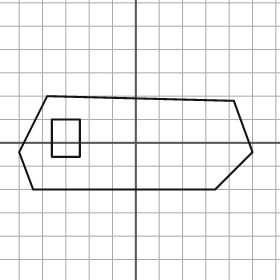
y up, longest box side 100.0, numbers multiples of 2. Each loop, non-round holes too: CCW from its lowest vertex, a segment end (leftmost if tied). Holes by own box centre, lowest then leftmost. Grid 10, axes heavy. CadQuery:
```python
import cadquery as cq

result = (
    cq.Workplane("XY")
    .moveTo(-44.0, -20.0)
    .lineTo(34.0, -20.0)
    .lineTo(50.0, -4.0)
    .lineTo(42.0, 18.0)
    .lineTo(-38.0, 20.0)
    .lineTo(-50.0, -4.0)
    .close()
    .moveTo(-36.0, -6.0)
    .lineTo(-24.0, -6.0)
    .lineTo(-24.0, 10.0)
    .lineTo(-36.0, 10.0)
    .close()
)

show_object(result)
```